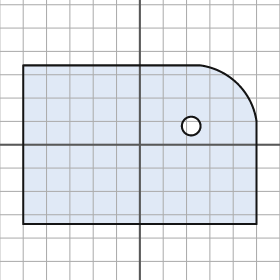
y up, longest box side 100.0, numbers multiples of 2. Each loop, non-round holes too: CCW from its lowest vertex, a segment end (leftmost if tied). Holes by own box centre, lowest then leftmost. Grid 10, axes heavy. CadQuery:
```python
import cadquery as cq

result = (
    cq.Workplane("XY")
    .moveTo(-50.0, -34.0)
    .lineTo(50.0, -34.0)
    .lineTo(50.0, 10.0)
    .threePointArc((42.0, 26.0), (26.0, 34.0))
    .lineTo(-50.0, 34.0)
    .close()
    .moveTo(22.0, 8.0)
    .circle(4.0)
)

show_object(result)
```